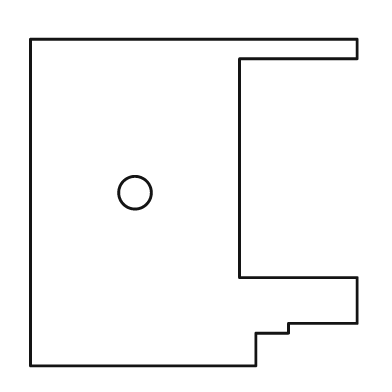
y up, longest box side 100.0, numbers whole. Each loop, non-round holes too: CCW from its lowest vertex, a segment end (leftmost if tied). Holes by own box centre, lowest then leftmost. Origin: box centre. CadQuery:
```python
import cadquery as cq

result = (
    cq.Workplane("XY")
    .moveTo(-50.0, -50.0)
    .lineTo(19.0, -50.0)
    .lineTo(19.0, -40.0)
    .lineTo(29.0, -40.0)
    .lineTo(29.0, -37.0)
    .lineTo(50.0, -37.0)
    .lineTo(50.0, -23.0)
    .lineTo(14.0, -23.0)
    .lineTo(14.0, 44.0)
    .lineTo(50.0, 44.0)
    .lineTo(50.0, 50.0)
    .lineTo(-50.0, 50.0)
    .close()
    .moveTo(-18.0, 3.0)
    .circle(5.0)
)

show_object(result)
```